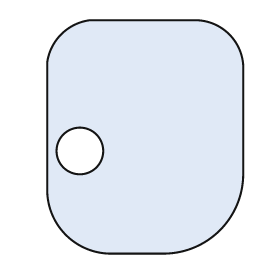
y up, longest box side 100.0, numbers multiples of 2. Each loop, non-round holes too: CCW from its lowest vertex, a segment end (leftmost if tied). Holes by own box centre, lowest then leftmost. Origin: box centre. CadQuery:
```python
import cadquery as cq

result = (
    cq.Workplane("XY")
    .moveTo(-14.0, -50.0)
    .lineTo(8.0, -50.0)
    .threePointArc((32.0, -40.0), (42.0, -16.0))
    .lineTo(42.0, 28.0)
    .threePointArc((36.0, 44.0), (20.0, 50.0))
    .lineTo(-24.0, 50.0)
    .threePointArc((-36.0, 44.0), (-42.0, 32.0))
    .lineTo(-42.0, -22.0)
    .threePointArc((-34.0, -42.0), (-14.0, -50.0))
    .close()
    .moveTo(-28.0, -6.0)
    .circle(10.0)
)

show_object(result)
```